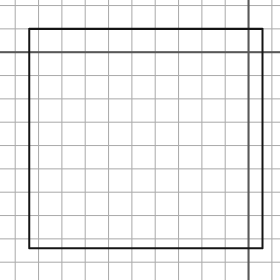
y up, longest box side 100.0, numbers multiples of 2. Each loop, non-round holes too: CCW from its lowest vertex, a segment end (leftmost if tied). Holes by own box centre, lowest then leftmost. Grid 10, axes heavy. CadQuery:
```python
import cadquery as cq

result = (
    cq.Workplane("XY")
    .moveTo(-94.0, -84.0)
    .lineTo(6.0, -84.0)
    .lineTo(6.0, 10.0)
    .lineTo(-94.0, 10.0)
    .close()
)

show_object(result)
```